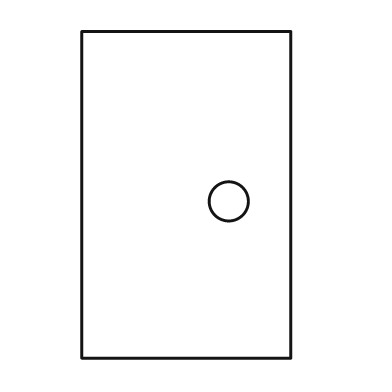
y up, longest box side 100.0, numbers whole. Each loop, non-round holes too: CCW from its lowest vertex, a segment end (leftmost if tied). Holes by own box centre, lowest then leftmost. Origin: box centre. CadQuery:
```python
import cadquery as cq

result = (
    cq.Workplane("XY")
    .moveTo(-32.0, -50.0)
    .lineTo(32.0, -50.0)
    .lineTo(32.0, 50.0)
    .lineTo(-32.0, 50.0)
    .close()
    .moveTo(13.0, -2.0)
    .circle(6.0)
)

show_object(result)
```